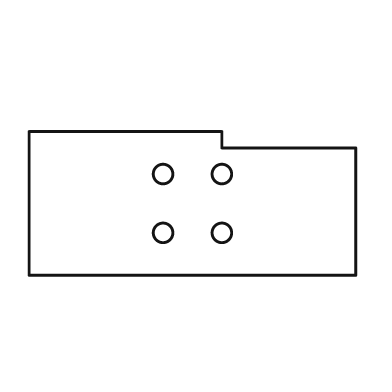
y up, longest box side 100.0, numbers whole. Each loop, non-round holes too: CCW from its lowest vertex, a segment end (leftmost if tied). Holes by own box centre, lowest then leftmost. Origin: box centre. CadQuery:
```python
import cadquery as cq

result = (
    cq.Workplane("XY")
    .moveTo(-50.0, -22.0)
    .lineTo(50.0, -22.0)
    .lineTo(50.0, 17.0)
    .lineTo(9.0, 17.0)
    .lineTo(9.0, 22.0)
    .lineTo(-50.0, 22.0)
    .close()
    .moveTo(-9.0, -9.0)
    .circle(3.0)
    .moveTo(9.0, -9.0)
    .circle(3.0)
    .moveTo(-9.0, 9.0)
    .circle(3.0)
    .moveTo(9.0, 9.0)
    .circle(3.0)
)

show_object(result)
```